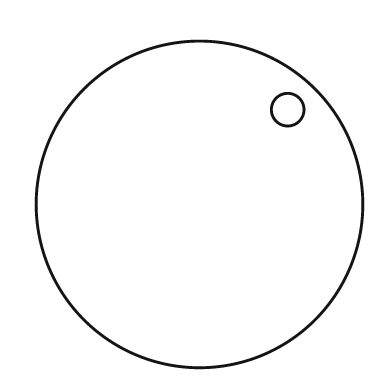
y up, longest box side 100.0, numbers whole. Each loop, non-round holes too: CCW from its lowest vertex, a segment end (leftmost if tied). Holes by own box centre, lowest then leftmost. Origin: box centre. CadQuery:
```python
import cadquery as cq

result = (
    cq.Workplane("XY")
    .moveTo(0.0, 0.0)
    .circle(50.0)
    .moveTo(27.0, 29.0)
    .circle(5.0)
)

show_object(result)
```